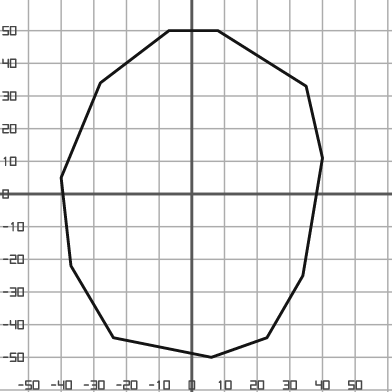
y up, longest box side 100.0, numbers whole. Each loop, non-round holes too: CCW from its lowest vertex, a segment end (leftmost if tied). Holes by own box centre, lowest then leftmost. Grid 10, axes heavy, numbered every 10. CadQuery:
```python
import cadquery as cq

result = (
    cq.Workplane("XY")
    .moveTo(6.0, -50.0)
    .lineTo(23.0, -44.0)
    .lineTo(34.0, -25.0)
    .lineTo(40.0, 11.0)
    .lineTo(35.0, 33.0)
    .lineTo(8.0, 50.0)
    .lineTo(-7.0, 50.0)
    .lineTo(-28.0, 34.0)
    .lineTo(-40.0, 5.0)
    .lineTo(-37.0, -22.0)
    .lineTo(-24.0, -44.0)
    .close()
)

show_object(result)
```